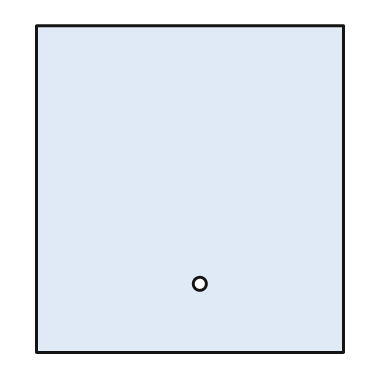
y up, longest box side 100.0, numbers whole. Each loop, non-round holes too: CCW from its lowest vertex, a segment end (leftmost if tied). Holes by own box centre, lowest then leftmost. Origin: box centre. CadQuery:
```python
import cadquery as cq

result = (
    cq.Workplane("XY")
    .moveTo(-47.0, -50.0)
    .lineTo(47.0, -50.0)
    .lineTo(47.0, 50.0)
    .lineTo(-47.0, 50.0)
    .close()
    .moveTo(3.0, -29.0)
    .circle(2.0)
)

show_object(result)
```